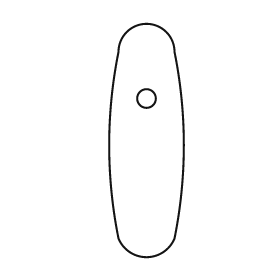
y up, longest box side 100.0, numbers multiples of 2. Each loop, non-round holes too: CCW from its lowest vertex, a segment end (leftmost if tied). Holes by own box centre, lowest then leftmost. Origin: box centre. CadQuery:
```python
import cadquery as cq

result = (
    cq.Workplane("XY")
    .moveTo(-12.0, -42.0)
    .threePointArc((0.0, -50.0), (12.0, -42.0))
    .threePointArc((16.0, -2.0), (12.0, 38.0))
    .threePointArc((0.0, 50.0), (-12.0, 38.0))
    .threePointArc((-16.0, -2.0), (-12.0, -42.0))
    .close()
    .moveTo(0.0, 18.0)
    .circle(4.0)
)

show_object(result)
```